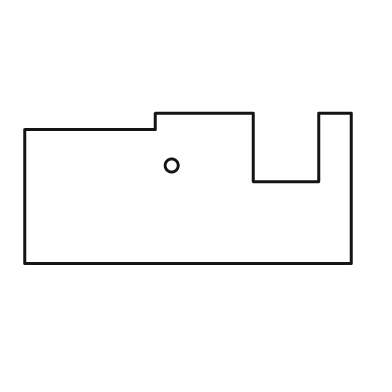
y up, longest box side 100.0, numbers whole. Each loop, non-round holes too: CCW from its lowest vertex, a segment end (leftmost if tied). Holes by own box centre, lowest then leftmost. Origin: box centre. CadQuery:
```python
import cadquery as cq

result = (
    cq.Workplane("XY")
    .moveTo(-50.0, -23.0)
    .lineTo(50.0, -23.0)
    .lineTo(50.0, 23.0)
    .lineTo(40.0, 23.0)
    .lineTo(40.0, 2.0)
    .lineTo(20.0, 2.0)
    .lineTo(20.0, 23.0)
    .lineTo(-10.0, 23.0)
    .lineTo(-10.0, 18.0)
    .lineTo(-50.0, 18.0)
    .close()
    .moveTo(-5.0, 7.0)
    .circle(2.0)
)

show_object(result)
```